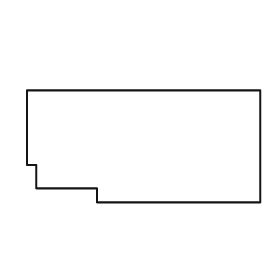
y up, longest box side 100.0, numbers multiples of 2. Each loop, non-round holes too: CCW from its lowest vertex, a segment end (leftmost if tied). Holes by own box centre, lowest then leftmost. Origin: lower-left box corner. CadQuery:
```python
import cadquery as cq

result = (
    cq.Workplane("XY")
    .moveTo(30.0, 0.0)
    .lineTo(100.0, 0.0)
    .lineTo(100.0, 48.0)
    .lineTo(0.0, 48.0)
    .lineTo(0.0, 16.0)
    .lineTo(4.0, 16.0)
    .lineTo(4.0, 6.0)
    .lineTo(30.0, 6.0)
    .close()
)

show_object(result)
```